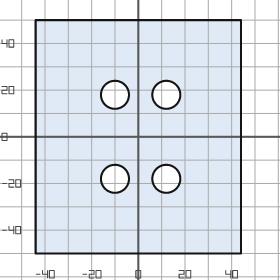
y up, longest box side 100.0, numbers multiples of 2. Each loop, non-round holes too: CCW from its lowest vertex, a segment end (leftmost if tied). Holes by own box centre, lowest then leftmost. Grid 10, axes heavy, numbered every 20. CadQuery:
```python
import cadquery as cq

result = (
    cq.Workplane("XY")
    .moveTo(-44.0, -50.0)
    .lineTo(44.0, -50.0)
    .lineTo(44.0, 50.0)
    .lineTo(-44.0, 50.0)
    .close()
    .moveTo(-10.0, -18.0)
    .circle(6.0)
    .moveTo(12.0, -18.0)
    .circle(6.0)
    .moveTo(-10.0, 18.0)
    .circle(6.0)
    .moveTo(12.0, 18.0)
    .circle(6.0)
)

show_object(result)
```